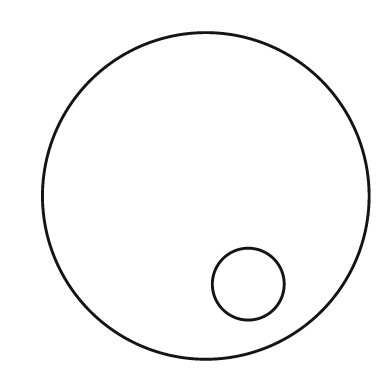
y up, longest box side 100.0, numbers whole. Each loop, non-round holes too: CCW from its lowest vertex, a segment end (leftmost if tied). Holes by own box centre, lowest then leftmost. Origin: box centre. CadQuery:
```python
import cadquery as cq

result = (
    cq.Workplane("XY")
    .moveTo(0.0, 0.0)
    .circle(50.0)
    .moveTo(13.0, -27.0)
    .circle(11.0)
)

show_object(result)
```